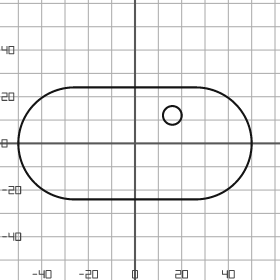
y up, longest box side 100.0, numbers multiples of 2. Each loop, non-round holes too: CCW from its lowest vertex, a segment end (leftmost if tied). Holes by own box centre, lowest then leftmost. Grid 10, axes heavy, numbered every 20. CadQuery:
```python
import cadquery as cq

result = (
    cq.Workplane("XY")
    .moveTo(-26.0, -24.0)
    .lineTo(26.0, -24.0)
    .threePointArc((50.0, 0.0), (26.0, 24.0))
    .lineTo(-26.0, 24.0)
    .threePointArc((-50.0, 0.0), (-26.0, -24.0))
    .close()
    .moveTo(16.0, 12.0)
    .circle(4.0)
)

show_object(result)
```